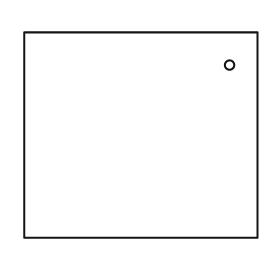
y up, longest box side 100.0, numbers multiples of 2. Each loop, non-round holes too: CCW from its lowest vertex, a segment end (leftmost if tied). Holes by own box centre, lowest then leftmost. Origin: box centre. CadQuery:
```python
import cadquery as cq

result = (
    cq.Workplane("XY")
    .moveTo(-50.0, -44.0)
    .lineTo(50.0, -44.0)
    .lineTo(50.0, 44.0)
    .lineTo(-50.0, 44.0)
    .close()
    .moveTo(38.0, 30.0)
    .circle(2.0)
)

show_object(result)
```